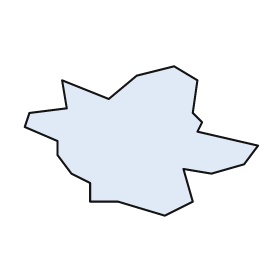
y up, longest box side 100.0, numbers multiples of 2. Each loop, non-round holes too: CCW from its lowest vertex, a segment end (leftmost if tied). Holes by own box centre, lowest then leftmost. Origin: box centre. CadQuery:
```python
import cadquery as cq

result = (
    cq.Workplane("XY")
    .moveTo(10.0, -32.0)
    .lineTo(22.0, -26.0)
    .lineTo(18.0, -12.0)
    .lineTo(30.0, -14.0)
    .lineTo(44.0, -10.0)
    .lineTo(50.0, -2.0)
    .lineTo(24.0, 4.0)
    .lineTo(26.0, 8.0)
    .lineTo(22.0, 12.0)
    .lineTo(24.0, 26.0)
    .lineTo(14.0, 32.0)
    .lineTo(-2.0, 28.0)
    .lineTo(-14.0, 18.0)
    .lineTo(-34.0, 26.0)
    .lineTo(-32.0, 14.0)
    .lineTo(-48.0, 12.0)
    .lineTo(-50.0, 6.0)
    .lineTo(-36.0, 0.0)
    .lineTo(-36.0, -6.0)
    .lineTo(-30.0, -14.0)
    .lineTo(-22.0, -18.0)
    .lineTo(-22.0, -26.0)
    .lineTo(-10.0, -26.0)
    .close()
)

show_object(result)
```